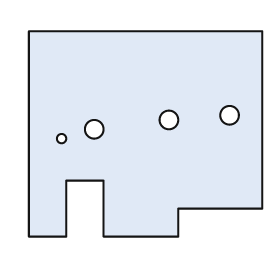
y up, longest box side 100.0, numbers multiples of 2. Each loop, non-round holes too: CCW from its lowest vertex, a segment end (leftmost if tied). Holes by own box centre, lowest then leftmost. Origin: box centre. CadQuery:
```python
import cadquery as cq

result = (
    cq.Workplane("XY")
    .moveTo(-50.0, -44.0)
    .lineTo(-34.0, -44.0)
    .lineTo(-34.0, -20.0)
    .lineTo(-18.0, -20.0)
    .lineTo(-18.0, -44.0)
    .lineTo(14.0, -44.0)
    .lineTo(14.0, -32.0)
    .lineTo(50.0, -32.0)
    .lineTo(50.0, 44.0)
    .lineTo(-50.0, 44.0)
    .close()
    .moveTo(-36.0, -2.0)
    .circle(2.0)
    .moveTo(-22.0, 2.0)
    .circle(4.0)
    .moveTo(10.0, 6.0)
    .circle(4.0)
    .moveTo(36.0, 8.0)
    .circle(4.0)
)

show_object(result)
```